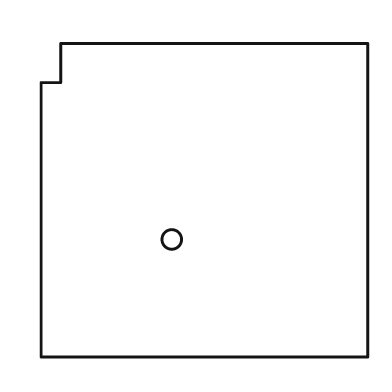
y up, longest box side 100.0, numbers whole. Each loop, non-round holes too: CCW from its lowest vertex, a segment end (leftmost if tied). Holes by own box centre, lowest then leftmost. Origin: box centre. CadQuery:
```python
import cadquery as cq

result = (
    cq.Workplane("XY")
    .moveTo(-50.0, -48.0)
    .lineTo(50.0, -48.0)
    .lineTo(50.0, 48.0)
    .lineTo(-44.0, 48.0)
    .lineTo(-44.0, 36.0)
    .lineTo(-50.0, 36.0)
    .close()
    .moveTo(-10.0, -12.0)
    .circle(3.0)
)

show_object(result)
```